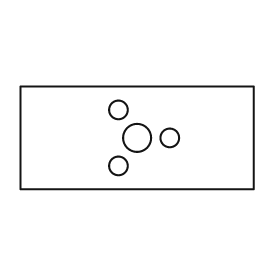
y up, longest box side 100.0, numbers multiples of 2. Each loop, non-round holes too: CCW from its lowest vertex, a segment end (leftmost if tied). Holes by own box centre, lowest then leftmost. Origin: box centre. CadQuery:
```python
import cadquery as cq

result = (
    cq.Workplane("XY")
    .moveTo(-50.0, -22.0)
    .lineTo(50.0, -22.0)
    .lineTo(50.0, 22.0)
    .lineTo(-50.0, 22.0)
    .close()
    .moveTo(-8.0, -12.0)
    .circle(4.0)
    .moveTo(0.0, 0.0)
    .circle(6.0)
    .moveTo(14.0, 0.0)
    .circle(4.0)
    .moveTo(-8.0, 12.0)
    .circle(4.0)
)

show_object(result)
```